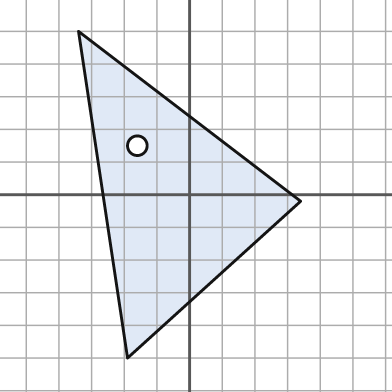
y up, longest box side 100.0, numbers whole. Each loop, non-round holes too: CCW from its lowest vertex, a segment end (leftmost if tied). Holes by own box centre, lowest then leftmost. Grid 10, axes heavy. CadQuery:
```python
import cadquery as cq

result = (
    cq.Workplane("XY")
    .moveTo(-19.0, -50.0)
    .lineTo(34.0, -2.0)
    .lineTo(-34.0, 50.0)
    .close()
    .moveTo(-16.0, 15.0)
    .circle(3.0)
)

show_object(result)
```